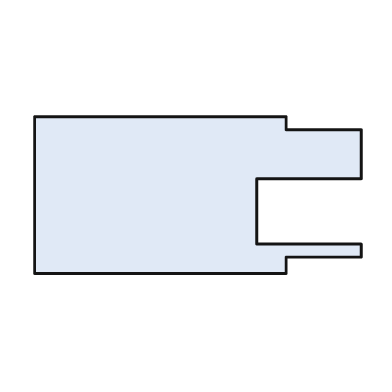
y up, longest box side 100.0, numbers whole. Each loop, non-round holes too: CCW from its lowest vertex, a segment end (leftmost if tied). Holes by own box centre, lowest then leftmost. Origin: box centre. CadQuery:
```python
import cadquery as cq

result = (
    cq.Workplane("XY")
    .moveTo(-50.0, -24.0)
    .lineTo(27.0, -24.0)
    .lineTo(27.0, -19.0)
    .lineTo(50.0, -19.0)
    .lineTo(50.0, -15.0)
    .lineTo(18.0, -15.0)
    .lineTo(18.0, 5.0)
    .lineTo(50.0, 5.0)
    .lineTo(50.0, 20.0)
    .lineTo(27.0, 20.0)
    .lineTo(27.0, 24.0)
    .lineTo(-50.0, 24.0)
    .close()
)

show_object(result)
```